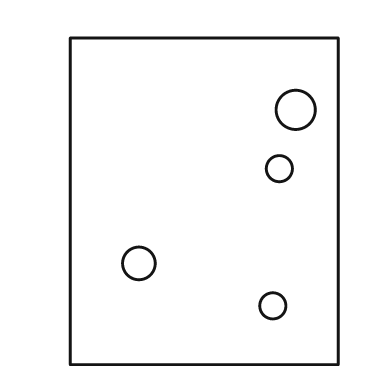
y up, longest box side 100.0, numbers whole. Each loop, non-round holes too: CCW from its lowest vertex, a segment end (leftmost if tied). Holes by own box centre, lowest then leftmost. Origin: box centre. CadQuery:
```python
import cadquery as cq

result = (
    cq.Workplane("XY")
    .moveTo(-41.0, -50.0)
    .lineTo(41.0, -50.0)
    .lineTo(41.0, 50.0)
    .lineTo(-41.0, 50.0)
    .close()
    .moveTo(21.0, -32.0)
    .circle(4.0)
    .moveTo(-20.0, -19.0)
    .circle(5.0)
    .moveTo(23.0, 10.0)
    .circle(4.0)
    .moveTo(28.0, 28.0)
    .circle(6.0)
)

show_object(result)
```